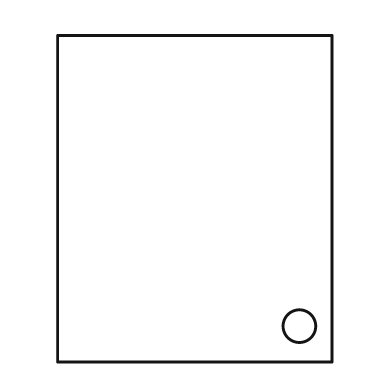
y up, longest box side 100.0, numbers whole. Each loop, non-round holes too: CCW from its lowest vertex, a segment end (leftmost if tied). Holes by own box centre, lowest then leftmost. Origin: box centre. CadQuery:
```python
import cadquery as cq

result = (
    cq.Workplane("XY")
    .moveTo(-42.0, -50.0)
    .lineTo(42.0, -50.0)
    .lineTo(42.0, 50.0)
    .lineTo(-42.0, 50.0)
    .close()
    .moveTo(32.0, -39.0)
    .circle(5.0)
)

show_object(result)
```